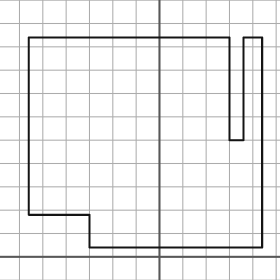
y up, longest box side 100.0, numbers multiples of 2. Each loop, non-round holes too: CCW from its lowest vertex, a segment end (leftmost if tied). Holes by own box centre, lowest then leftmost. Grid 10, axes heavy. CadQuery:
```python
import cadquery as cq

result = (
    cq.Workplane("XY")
    .moveTo(-30.0, 4.0)
    .lineTo(44.0, 4.0)
    .lineTo(44.0, 94.0)
    .lineTo(36.0, 94.0)
    .lineTo(36.0, 50.0)
    .lineTo(30.0, 50.0)
    .lineTo(30.0, 94.0)
    .lineTo(-56.0, 94.0)
    .lineTo(-56.0, 18.0)
    .lineTo(-30.0, 18.0)
    .close()
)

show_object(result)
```